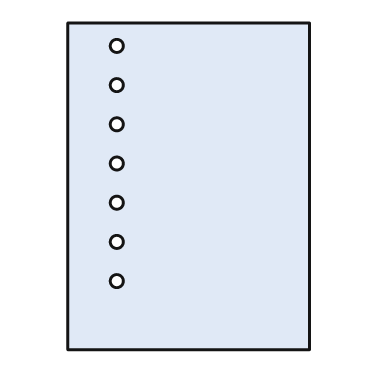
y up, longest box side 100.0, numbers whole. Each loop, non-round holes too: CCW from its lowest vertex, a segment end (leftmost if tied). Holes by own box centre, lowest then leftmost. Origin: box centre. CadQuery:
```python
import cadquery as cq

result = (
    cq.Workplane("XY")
    .moveTo(-37.0, -50.0)
    .lineTo(37.0, -50.0)
    .lineTo(37.0, 50.0)
    .lineTo(-37.0, 50.0)
    .close()
    .moveTo(-22.0, -29.0)
    .circle(2.0)
    .moveTo(-22.0, -17.0)
    .circle(2.0)
    .moveTo(-22.0, -5.0)
    .circle(2.0)
    .moveTo(-22.0, 7.0)
    .circle(2.0)
    .moveTo(-22.0, 19.0)
    .circle(2.0)
    .moveTo(-22.0, 31.0)
    .circle(2.0)
    .moveTo(-22.0, 43.0)
    .circle(2.0)
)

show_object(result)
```